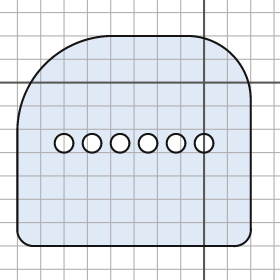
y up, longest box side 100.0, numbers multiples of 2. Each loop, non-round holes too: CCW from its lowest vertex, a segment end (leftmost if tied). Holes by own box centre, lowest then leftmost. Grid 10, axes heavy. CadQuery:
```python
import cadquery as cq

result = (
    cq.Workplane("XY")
    .moveTo(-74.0, -70.0)
    .lineTo(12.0, -70.0)
    .threePointArc((18.0, -68.0), (20.0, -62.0))
    .lineTo(20.0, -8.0)
    .threePointArc((12.0, 12.0), (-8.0, 20.0))
    .lineTo(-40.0, 20.0)
    .threePointArc((-68.0, 8.0), (-80.0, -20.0))
    .lineTo(-80.0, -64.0)
    .threePointArc((-78.0, -68.0), (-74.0, -70.0))
    .close()
    .moveTo(-60.0, -26.0)
    .circle(4.0)
    .moveTo(-48.0, -26.0)
    .circle(4.0)
    .moveTo(-36.0, -26.0)
    .circle(4.0)
    .moveTo(-24.0, -26.0)
    .circle(4.0)
    .moveTo(-12.0, -26.0)
    .circle(4.0)
    .moveTo(0.0, -26.0)
    .circle(4.0)
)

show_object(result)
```